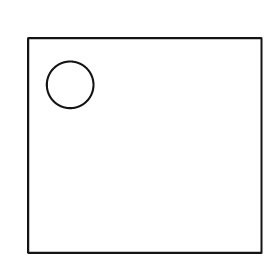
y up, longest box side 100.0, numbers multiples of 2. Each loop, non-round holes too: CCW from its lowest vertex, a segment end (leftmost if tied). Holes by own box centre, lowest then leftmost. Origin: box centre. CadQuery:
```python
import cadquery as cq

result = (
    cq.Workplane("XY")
    .moveTo(-50.0, -46.0)
    .lineTo(50.0, -46.0)
    .lineTo(50.0, 46.0)
    .lineTo(-50.0, 46.0)
    .close()
    .moveTo(-32.0, 26.0)
    .circle(10.0)
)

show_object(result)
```